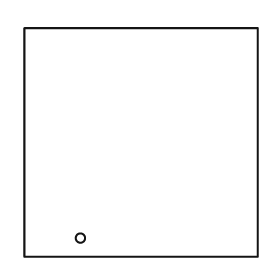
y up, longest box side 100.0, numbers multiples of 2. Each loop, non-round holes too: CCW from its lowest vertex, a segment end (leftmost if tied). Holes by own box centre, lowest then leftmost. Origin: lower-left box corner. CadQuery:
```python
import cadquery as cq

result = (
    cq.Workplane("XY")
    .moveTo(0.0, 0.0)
    .lineTo(100.0, 0.0)
    .lineTo(100.0, 98.0)
    .lineTo(0.0, 98.0)
    .close()
    .moveTo(24.0, 8.0)
    .circle(2.0)
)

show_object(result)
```